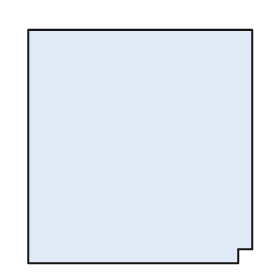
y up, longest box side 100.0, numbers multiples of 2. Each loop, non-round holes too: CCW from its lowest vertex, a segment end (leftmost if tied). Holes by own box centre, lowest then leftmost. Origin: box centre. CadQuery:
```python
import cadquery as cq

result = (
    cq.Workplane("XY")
    .moveTo(-48.0, -50.0)
    .lineTo(42.0, -50.0)
    .lineTo(42.0, -44.0)
    .lineTo(48.0, -44.0)
    .lineTo(48.0, 50.0)
    .lineTo(-48.0, 50.0)
    .close()
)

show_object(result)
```